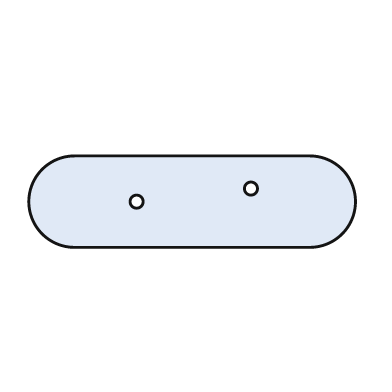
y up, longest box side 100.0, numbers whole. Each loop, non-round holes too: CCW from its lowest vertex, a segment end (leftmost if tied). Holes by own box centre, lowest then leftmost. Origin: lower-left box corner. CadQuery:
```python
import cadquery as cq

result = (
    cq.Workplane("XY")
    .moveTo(14.0, 0.0)
    .lineTo(86.0, 0.0)
    .threePointArc((100.0, 14.0), (86.0, 28.0))
    .lineTo(14.0, 28.0)
    .threePointArc((0.0, 14.0), (14.0, 0.0))
    .close()
    .moveTo(33.0, 14.0)
    .circle(2.0)
    .moveTo(68.0, 18.0)
    .circle(2.0)
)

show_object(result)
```